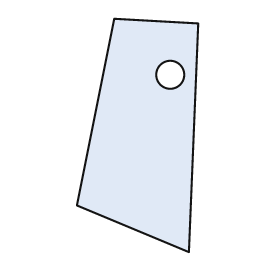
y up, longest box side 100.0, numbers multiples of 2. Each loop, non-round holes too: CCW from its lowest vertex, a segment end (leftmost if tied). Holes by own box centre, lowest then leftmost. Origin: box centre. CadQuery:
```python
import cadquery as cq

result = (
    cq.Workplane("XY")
    .moveTo(22.0, -50.0)
    .lineTo(26.0, 48.0)
    .lineTo(-10.0, 50.0)
    .lineTo(-26.0, -30.0)
    .close()
    .moveTo(14.0, 26.0)
    .circle(6.0)
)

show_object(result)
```